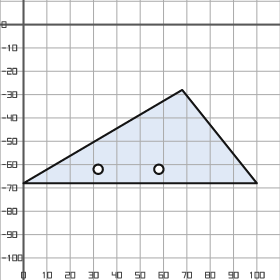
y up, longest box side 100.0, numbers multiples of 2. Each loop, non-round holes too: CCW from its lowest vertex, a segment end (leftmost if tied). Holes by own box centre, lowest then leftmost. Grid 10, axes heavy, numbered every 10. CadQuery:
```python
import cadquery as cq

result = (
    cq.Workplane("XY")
    .moveTo(0.0, -68.0)
    .lineTo(100.0, -68.0)
    .lineTo(68.0, -28.0)
    .close()
    .moveTo(32.0, -62.0)
    .circle(2.0)
    .moveTo(58.0, -62.0)
    .circle(2.0)
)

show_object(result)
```